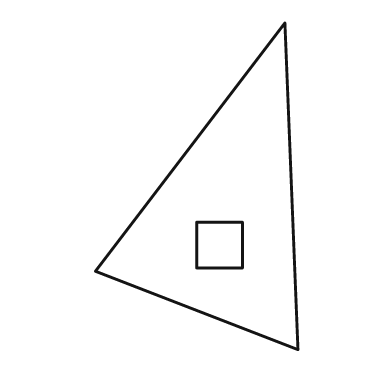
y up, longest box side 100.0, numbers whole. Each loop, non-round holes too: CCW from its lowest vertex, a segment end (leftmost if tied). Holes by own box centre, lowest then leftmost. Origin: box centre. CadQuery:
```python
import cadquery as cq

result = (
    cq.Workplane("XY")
    .moveTo(31.0, -50.0)
    .lineTo(27.0, 50.0)
    .lineTo(-31.0, -26.0)
    .close()
    .moveTo(0.0, -25.0)
    .lineTo(14.0, -25.0)
    .lineTo(14.0, -11.0)
    .lineTo(0.0, -11.0)
    .close()
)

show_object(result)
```